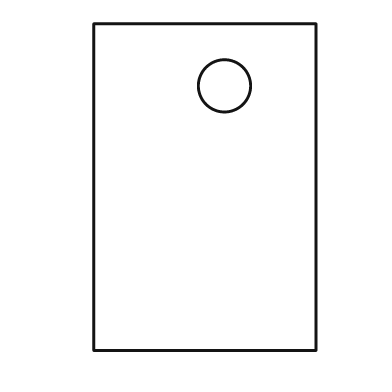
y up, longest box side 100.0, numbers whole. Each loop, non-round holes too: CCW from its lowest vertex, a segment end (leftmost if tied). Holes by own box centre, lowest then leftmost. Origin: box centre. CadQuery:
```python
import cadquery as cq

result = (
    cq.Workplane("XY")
    .moveTo(-34.0, -50.0)
    .lineTo(34.0, -50.0)
    .lineTo(34.0, 50.0)
    .lineTo(-34.0, 50.0)
    .close()
    .moveTo(6.0, 31.0)
    .circle(8.0)
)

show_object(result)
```